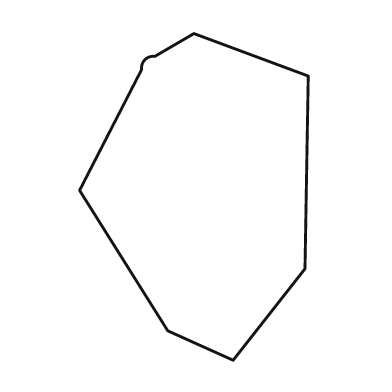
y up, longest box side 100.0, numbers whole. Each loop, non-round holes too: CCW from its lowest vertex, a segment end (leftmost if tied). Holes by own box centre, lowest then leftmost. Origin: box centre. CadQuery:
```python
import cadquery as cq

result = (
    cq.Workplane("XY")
    .moveTo(12.0, -50.0)
    .lineTo(34.0, -22.0)
    .lineTo(35.0, 37.0)
    .lineTo(0.0, 50.0)
    .lineTo(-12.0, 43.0)
    .threePointArc((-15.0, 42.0), (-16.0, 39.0))
    .lineTo(-35.0, 2.0)
    .lineTo(-8.0, -41.0)
    .close()
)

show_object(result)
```